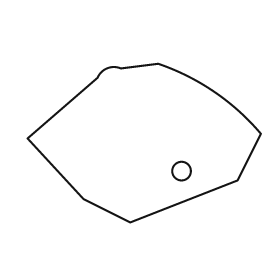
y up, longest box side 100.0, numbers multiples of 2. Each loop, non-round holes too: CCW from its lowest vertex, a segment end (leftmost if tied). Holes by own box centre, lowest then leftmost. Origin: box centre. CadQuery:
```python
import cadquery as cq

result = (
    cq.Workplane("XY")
    .moveTo(-6.0, -34.0)
    .lineTo(40.0, -16.0)
    .lineTo(50.0, 4.0)
    .threePointArc((30.0, 22.0), (6.0, 34.0))
    .lineTo(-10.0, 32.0)
    .threePointArc((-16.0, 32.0), (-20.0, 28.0))
    .lineTo(-50.0, 2.0)
    .lineTo(-26.0, -24.0)
    .close()
    .moveTo(16.0, -12.0)
    .circle(4.0)
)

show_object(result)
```